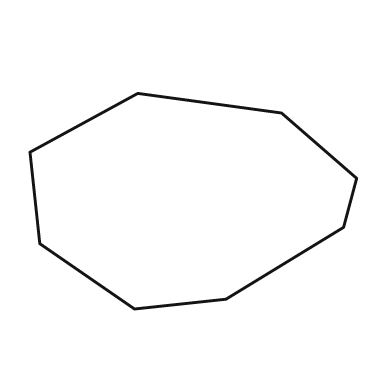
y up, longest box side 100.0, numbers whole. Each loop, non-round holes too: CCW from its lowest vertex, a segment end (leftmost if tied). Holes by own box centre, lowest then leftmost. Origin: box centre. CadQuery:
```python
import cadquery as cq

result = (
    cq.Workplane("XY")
    .moveTo(-18.0, -33.0)
    .lineTo(10.0, -30.0)
    .lineTo(46.0, -8.0)
    .lineTo(50.0, 7.0)
    .lineTo(27.0, 27.0)
    .lineTo(-17.0, 33.0)
    .lineTo(-50.0, 15.0)
    .lineTo(-47.0, -13.0)
    .close()
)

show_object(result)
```